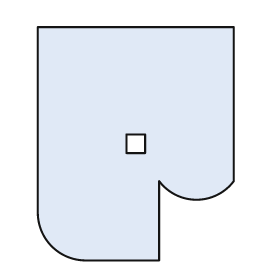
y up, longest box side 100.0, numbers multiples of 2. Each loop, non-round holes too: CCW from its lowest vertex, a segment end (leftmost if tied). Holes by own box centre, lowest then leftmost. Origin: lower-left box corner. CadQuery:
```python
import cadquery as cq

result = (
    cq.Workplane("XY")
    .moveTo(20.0, 0.0)
    .lineTo(52.0, 0.0)
    .lineTo(52.0, 34.0)
    .threePointArc((68.0, 26.0), (84.0, 34.0))
    .lineTo(84.0, 100.0)
    .lineTo(0.0, 100.0)
    .lineTo(0.0, 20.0)
    .threePointArc((6.0, 6.0), (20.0, 0.0))
    .close()
    .moveTo(38.0, 46.0)
    .lineTo(46.0, 46.0)
    .lineTo(46.0, 54.0)
    .lineTo(38.0, 54.0)
    .close()
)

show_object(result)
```